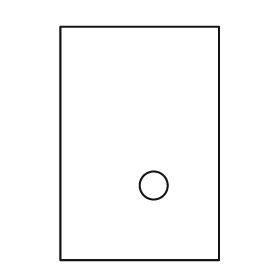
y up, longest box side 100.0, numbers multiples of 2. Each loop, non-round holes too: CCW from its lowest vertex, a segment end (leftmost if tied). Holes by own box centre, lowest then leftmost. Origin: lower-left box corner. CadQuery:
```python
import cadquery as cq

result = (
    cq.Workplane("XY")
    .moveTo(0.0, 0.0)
    .lineTo(68.0, 0.0)
    .lineTo(68.0, 100.0)
    .lineTo(0.0, 100.0)
    .close()
    .moveTo(40.0, 32.0)
    .circle(6.0)
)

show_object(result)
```